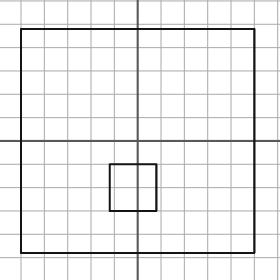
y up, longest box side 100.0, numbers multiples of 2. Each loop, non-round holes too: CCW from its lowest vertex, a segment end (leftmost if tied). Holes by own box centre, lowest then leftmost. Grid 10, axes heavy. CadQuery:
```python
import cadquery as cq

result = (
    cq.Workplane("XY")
    .moveTo(-50.0, -48.0)
    .lineTo(50.0, -48.0)
    .lineTo(50.0, 48.0)
    .lineTo(-50.0, 48.0)
    .close()
    .moveTo(-12.0, -30.0)
    .lineTo(8.0, -30.0)
    .lineTo(8.0, -10.0)
    .lineTo(-12.0, -10.0)
    .close()
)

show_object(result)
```